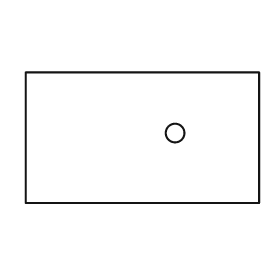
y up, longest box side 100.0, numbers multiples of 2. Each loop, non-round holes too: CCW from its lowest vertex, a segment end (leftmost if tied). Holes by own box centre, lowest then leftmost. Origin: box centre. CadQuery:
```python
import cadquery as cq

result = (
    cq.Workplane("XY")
    .moveTo(-50.0, -28.0)
    .lineTo(50.0, -28.0)
    .lineTo(50.0, 28.0)
    .lineTo(-50.0, 28.0)
    .close()
    .moveTo(14.0, 2.0)
    .circle(4.0)
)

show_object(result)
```